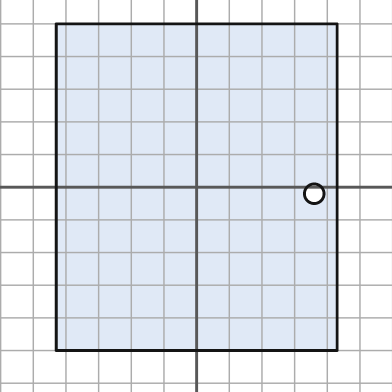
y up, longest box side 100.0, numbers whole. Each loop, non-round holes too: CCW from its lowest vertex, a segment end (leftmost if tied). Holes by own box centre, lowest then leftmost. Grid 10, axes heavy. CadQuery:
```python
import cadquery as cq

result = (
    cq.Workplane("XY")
    .moveTo(-43.0, -50.0)
    .lineTo(43.0, -50.0)
    .lineTo(43.0, 50.0)
    .lineTo(-43.0, 50.0)
    .close()
    .moveTo(36.0, -2.0)
    .circle(3.0)
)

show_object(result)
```